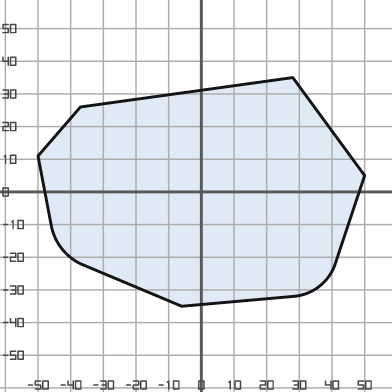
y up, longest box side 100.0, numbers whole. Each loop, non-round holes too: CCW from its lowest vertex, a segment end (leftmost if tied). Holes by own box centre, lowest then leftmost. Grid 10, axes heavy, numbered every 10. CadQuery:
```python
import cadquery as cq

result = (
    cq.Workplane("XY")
    .moveTo(-6.0, -35.0)
    .lineTo(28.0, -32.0)
    .threePointArc((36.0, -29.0), (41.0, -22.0))
    .lineTo(50.0, 5.0)
    .lineTo(28.0, 35.0)
    .lineTo(-37.0, 26.0)
    .lineTo(-50.0, 11.0)
    .lineTo(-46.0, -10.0)
    .threePointArc((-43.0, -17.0), (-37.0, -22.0))
    .close()
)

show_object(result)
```